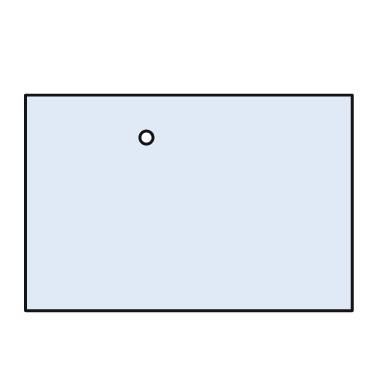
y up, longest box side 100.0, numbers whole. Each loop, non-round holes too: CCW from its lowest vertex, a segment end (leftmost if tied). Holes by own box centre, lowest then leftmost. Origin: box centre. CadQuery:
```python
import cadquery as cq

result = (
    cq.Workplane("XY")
    .moveTo(-50.0, -33.0)
    .lineTo(50.0, -33.0)
    .lineTo(50.0, 33.0)
    .lineTo(-50.0, 33.0)
    .close()
    .moveTo(-13.0, 20.0)
    .circle(2.0)
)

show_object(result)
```